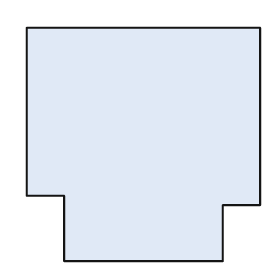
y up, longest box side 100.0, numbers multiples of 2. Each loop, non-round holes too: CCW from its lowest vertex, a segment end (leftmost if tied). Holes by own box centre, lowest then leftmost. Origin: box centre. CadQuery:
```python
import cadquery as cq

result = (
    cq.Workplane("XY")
    .moveTo(-34.0, -50.0)
    .lineTo(34.0, -50.0)
    .lineTo(34.0, -26.0)
    .lineTo(50.0, -26.0)
    .lineTo(50.0, 50.0)
    .lineTo(-50.0, 50.0)
    .lineTo(-50.0, -22.0)
    .lineTo(-34.0, -22.0)
    .close()
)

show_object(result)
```